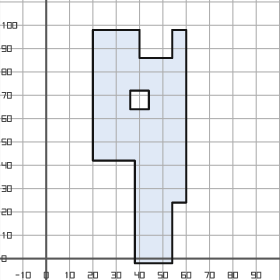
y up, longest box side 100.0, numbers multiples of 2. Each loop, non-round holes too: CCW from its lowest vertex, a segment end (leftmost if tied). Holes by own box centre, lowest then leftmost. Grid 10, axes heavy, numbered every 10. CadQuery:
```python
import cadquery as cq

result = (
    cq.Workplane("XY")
    .moveTo(38.0, -2.0)
    .lineTo(54.0, -2.0)
    .lineTo(54.0, 24.0)
    .lineTo(60.0, 24.0)
    .lineTo(60.0, 98.0)
    .lineTo(54.0, 98.0)
    .lineTo(54.0, 86.0)
    .lineTo(40.0, 86.0)
    .lineTo(40.0, 98.0)
    .lineTo(20.0, 98.0)
    .lineTo(20.0, 42.0)
    .lineTo(38.0, 42.0)
    .close()
    .moveTo(36.0, 64.0)
    .lineTo(44.0, 64.0)
    .lineTo(44.0, 72.0)
    .lineTo(36.0, 72.0)
    .close()
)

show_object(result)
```